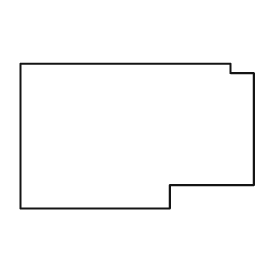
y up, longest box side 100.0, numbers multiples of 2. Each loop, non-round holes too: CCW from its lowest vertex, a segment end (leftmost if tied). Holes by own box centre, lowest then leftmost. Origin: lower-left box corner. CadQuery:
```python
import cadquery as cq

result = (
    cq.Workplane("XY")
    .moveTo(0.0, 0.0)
    .lineTo(64.0, 0.0)
    .lineTo(64.0, 10.0)
    .lineTo(100.0, 10.0)
    .lineTo(100.0, 58.0)
    .lineTo(90.0, 58.0)
    .lineTo(90.0, 62.0)
    .lineTo(0.0, 62.0)
    .close()
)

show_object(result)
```